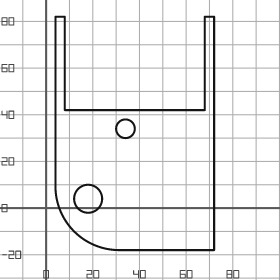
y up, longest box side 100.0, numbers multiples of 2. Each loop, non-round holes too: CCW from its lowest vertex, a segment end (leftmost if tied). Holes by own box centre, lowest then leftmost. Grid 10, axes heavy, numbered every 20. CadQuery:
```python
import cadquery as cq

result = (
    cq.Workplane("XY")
    .moveTo(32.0, -18.0)
    .lineTo(72.0, -18.0)
    .lineTo(72.0, 82.0)
    .lineTo(68.0, 82.0)
    .lineTo(68.0, 42.0)
    .lineTo(8.0, 42.0)
    .lineTo(8.0, 82.0)
    .lineTo(4.0, 82.0)
    .lineTo(4.0, 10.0)
    .threePointArc((12.0, -10.0), (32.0, -18.0))
    .close()
    .moveTo(18.0, 4.0)
    .circle(6.0)
    .moveTo(34.0, 34.0)
    .circle(4.0)
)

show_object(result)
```